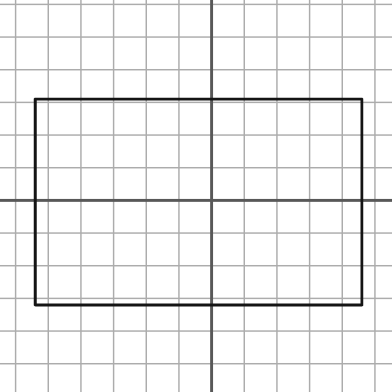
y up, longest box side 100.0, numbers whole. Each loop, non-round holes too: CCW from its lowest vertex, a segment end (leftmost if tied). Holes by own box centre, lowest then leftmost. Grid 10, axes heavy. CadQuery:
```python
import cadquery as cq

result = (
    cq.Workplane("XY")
    .moveTo(-54.0, -32.0)
    .lineTo(46.0, -32.0)
    .lineTo(46.0, 31.0)
    .lineTo(-54.0, 31.0)
    .close()
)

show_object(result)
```